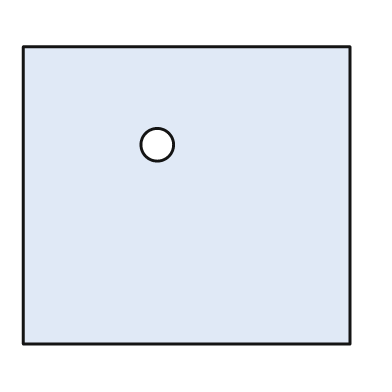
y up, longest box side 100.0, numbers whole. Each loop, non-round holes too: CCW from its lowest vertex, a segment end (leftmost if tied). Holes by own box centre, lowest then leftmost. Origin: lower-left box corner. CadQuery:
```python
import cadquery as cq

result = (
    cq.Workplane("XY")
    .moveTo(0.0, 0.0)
    .lineTo(100.0, 0.0)
    .lineTo(100.0, 91.0)
    .lineTo(0.0, 91.0)
    .close()
    .moveTo(41.0, 61.0)
    .circle(5.0)
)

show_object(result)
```